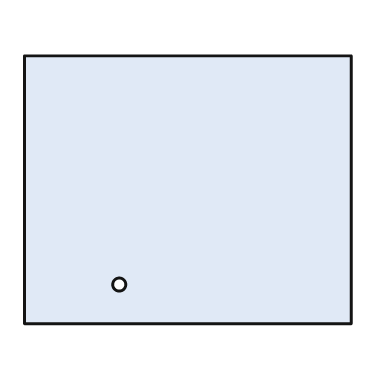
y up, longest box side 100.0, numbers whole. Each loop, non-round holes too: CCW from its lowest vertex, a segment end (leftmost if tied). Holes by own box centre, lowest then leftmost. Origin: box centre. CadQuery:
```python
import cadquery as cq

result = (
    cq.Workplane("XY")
    .moveTo(-50.0, -41.0)
    .lineTo(50.0, -41.0)
    .lineTo(50.0, 41.0)
    .lineTo(-50.0, 41.0)
    .close()
    .moveTo(-21.0, -29.0)
    .circle(2.0)
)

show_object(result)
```